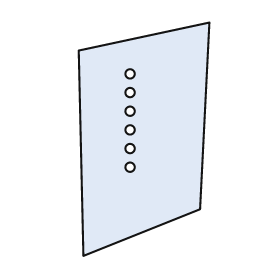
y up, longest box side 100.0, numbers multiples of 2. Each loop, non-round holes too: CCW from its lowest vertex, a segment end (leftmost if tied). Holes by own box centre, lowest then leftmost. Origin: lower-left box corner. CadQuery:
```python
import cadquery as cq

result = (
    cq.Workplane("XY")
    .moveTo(2.0, 0.0)
    .lineTo(52.0, 20.0)
    .lineTo(56.0, 100.0)
    .lineTo(0.0, 88.0)
    .close()
    .moveTo(22.0, 38.0)
    .circle(2.0)
    .moveTo(22.0, 46.0)
    .circle(2.0)
    .moveTo(22.0, 54.0)
    .circle(2.0)
    .moveTo(22.0, 62.0)
    .circle(2.0)
    .moveTo(22.0, 70.0)
    .circle(2.0)
    .moveTo(22.0, 78.0)
    .circle(2.0)
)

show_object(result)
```